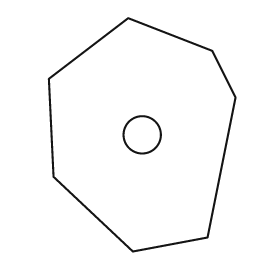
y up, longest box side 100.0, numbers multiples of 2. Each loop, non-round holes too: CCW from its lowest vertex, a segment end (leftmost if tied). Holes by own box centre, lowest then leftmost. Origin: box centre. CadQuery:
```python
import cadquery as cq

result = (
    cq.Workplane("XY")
    .moveTo(-4.0, -50.0)
    .lineTo(28.0, -44.0)
    .lineTo(40.0, 16.0)
    .lineTo(30.0, 36.0)
    .lineTo(-6.0, 50.0)
    .lineTo(-40.0, 24.0)
    .lineTo(-38.0, -18.0)
    .close()
    .moveTo(0.0, 0.0)
    .circle(8.0)
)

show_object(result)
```